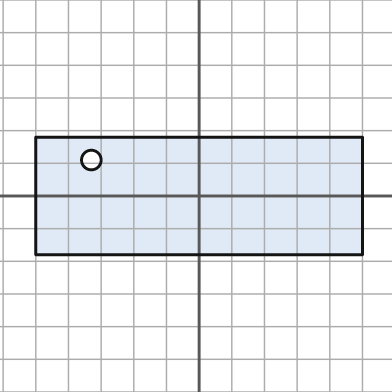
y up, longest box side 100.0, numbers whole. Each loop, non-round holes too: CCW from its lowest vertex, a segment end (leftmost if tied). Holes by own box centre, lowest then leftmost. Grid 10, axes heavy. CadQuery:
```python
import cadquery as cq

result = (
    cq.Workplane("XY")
    .moveTo(-50.0, -18.0)
    .lineTo(50.0, -18.0)
    .lineTo(50.0, 18.0)
    .lineTo(-50.0, 18.0)
    .close()
    .moveTo(-33.0, 11.0)
    .circle(3.0)
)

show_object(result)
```